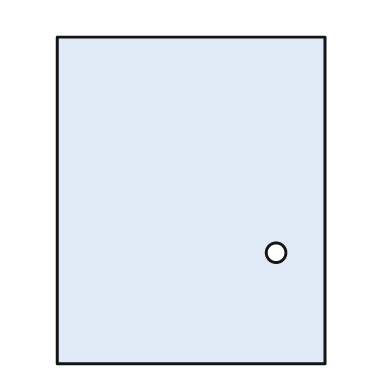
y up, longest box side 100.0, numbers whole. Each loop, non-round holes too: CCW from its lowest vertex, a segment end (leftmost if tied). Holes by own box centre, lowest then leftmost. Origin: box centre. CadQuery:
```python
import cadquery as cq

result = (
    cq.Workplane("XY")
    .moveTo(-41.0, -50.0)
    .lineTo(41.0, -50.0)
    .lineTo(41.0, 50.0)
    .lineTo(-41.0, 50.0)
    .close()
    .moveTo(26.0, -16.0)
    .circle(3.0)
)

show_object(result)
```